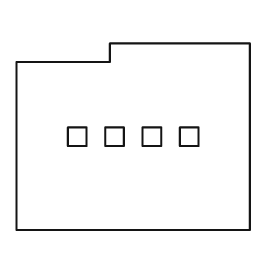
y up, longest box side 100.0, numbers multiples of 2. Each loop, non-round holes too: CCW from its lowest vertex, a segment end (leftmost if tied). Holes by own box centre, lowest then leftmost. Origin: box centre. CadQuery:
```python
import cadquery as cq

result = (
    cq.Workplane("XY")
    .moveTo(-50.0, -40.0)
    .lineTo(50.0, -40.0)
    .lineTo(50.0, 40.0)
    .lineTo(-10.0, 40.0)
    .lineTo(-10.0, 32.0)
    .lineTo(-50.0, 32.0)
    .close()
    .moveTo(-28.0, -4.0)
    .lineTo(-20.0, -4.0)
    .lineTo(-20.0, 4.0)
    .lineTo(-28.0, 4.0)
    .close()
    .moveTo(-12.0, -4.0)
    .lineTo(-4.0, -4.0)
    .lineTo(-4.0, 4.0)
    .lineTo(-12.0, 4.0)
    .close()
    .moveTo(4.0, -4.0)
    .lineTo(12.0, -4.0)
    .lineTo(12.0, 4.0)
    .lineTo(4.0, 4.0)
    .close()
    .moveTo(20.0, -4.0)
    .lineTo(28.0, -4.0)
    .lineTo(28.0, 4.0)
    .lineTo(20.0, 4.0)
    .close()
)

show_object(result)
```